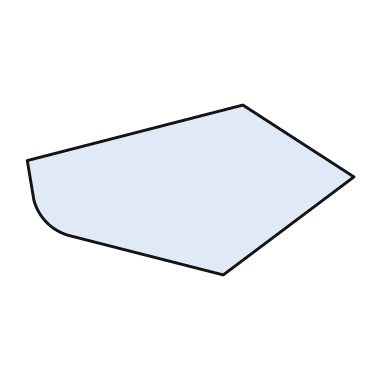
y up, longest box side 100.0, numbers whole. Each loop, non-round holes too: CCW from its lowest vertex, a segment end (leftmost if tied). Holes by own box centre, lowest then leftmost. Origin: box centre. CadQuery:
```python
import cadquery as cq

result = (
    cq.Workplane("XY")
    .moveTo(10.0, -26.0)
    .lineTo(50.0, 4.0)
    .lineTo(16.0, 26.0)
    .lineTo(-50.0, 9.0)
    .lineTo(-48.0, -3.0)
    .threePointArc((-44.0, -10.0), (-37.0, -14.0))
    .close()
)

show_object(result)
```